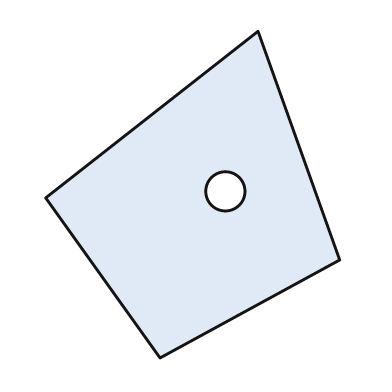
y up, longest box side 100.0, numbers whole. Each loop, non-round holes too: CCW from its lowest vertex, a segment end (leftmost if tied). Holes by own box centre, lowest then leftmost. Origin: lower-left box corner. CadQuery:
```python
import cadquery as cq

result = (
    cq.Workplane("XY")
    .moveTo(35.0, 0.0)
    .lineTo(90.0, 30.0)
    .lineTo(65.0, 100.0)
    .lineTo(0.0, 49.0)
    .close()
    .moveTo(55.0, 51.0)
    .circle(6.0)
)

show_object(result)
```